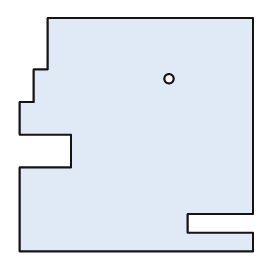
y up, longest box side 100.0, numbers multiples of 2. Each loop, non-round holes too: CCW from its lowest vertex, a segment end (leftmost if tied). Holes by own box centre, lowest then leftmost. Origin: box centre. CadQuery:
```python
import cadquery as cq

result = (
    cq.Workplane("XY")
    .moveTo(-50.0, -50.0)
    .lineTo(50.0, -50.0)
    .lineTo(50.0, -42.0)
    .lineTo(22.0, -42.0)
    .lineTo(22.0, -34.0)
    .lineTo(50.0, -34.0)
    .lineTo(50.0, 50.0)
    .lineTo(-38.0, 50.0)
    .lineTo(-38.0, 28.0)
    .lineTo(-44.0, 28.0)
    .lineTo(-44.0, 14.0)
    .lineTo(-50.0, 14.0)
    .lineTo(-50.0, 0.0)
    .lineTo(-28.0, 0.0)
    .lineTo(-28.0, -14.0)
    .lineTo(-50.0, -14.0)
    .close()
    .moveTo(14.0, 24.0)
    .circle(2.0)
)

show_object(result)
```